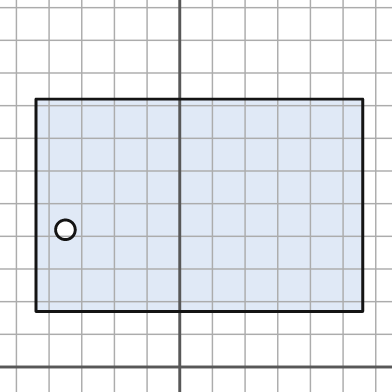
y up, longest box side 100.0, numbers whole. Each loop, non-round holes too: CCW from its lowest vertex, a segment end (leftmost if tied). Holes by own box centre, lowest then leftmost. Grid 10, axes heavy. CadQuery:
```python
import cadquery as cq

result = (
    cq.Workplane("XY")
    .moveTo(-44.0, 17.0)
    .lineTo(56.0, 17.0)
    .lineTo(56.0, 82.0)
    .lineTo(-44.0, 82.0)
    .close()
    .moveTo(-35.0, 42.0)
    .circle(3.0)
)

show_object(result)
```